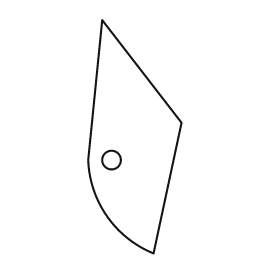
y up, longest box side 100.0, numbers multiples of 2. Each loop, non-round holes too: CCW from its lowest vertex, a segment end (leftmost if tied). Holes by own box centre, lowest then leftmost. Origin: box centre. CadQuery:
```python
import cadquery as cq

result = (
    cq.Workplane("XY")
    .moveTo(8.0, -50.0)
    .lineTo(20.0, 6.0)
    .lineTo(-14.0, 50.0)
    .lineTo(-20.0, -10.0)
    .threePointArc((-12.0, -34.0), (8.0, -50.0))
    .close()
    .moveTo(-10.0, -10.0)
    .circle(4.0)
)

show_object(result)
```